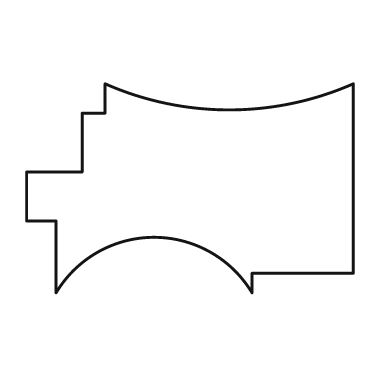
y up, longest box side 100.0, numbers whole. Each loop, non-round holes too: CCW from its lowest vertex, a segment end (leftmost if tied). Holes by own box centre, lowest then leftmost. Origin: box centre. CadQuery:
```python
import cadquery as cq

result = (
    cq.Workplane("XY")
    .moveTo(-41.0, -32.0)
    .threePointArc((-11.0, -15.0), (19.0, -32.0))
    .lineTo(19.0, -26.0)
    .lineTo(50.0, -26.0)
    .lineTo(50.0, 32.0)
    .threePointArc((12.0, 24.0), (-26.0, 32.0))
    .lineTo(-26.0, 23.0)
    .lineTo(-33.0, 23.0)
    .lineTo(-33.0, 5.0)
    .lineTo(-50.0, 5.0)
    .lineTo(-50.0, -10.0)
    .lineTo(-41.0, -10.0)
    .close()
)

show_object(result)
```